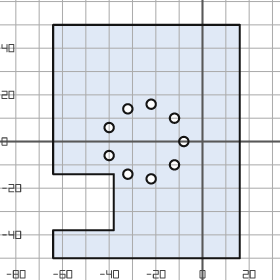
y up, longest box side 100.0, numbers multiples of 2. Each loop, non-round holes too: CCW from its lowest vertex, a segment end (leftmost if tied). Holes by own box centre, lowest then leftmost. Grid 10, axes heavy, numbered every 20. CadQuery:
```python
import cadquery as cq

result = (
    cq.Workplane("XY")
    .moveTo(-64.0, -50.0)
    .lineTo(16.0, -50.0)
    .lineTo(16.0, 50.0)
    .lineTo(-64.0, 50.0)
    .lineTo(-64.0, -14.0)
    .lineTo(-38.0, -14.0)
    .lineTo(-38.0, -38.0)
    .lineTo(-64.0, -38.0)
    .close()
    .moveTo(-22.0, -16.0)
    .circle(2.0)
    .moveTo(-32.0, -14.0)
    .circle(2.0)
    .moveTo(-12.0, -10.0)
    .circle(2.0)
    .moveTo(-40.0, -6.0)
    .circle(2.0)
    .moveTo(-8.0, 0.0)
    .circle(2.0)
    .moveTo(-40.0, 6.0)
    .circle(2.0)
    .moveTo(-12.0, 10.0)
    .circle(2.0)
    .moveTo(-32.0, 14.0)
    .circle(2.0)
    .moveTo(-22.0, 16.0)
    .circle(2.0)
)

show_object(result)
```